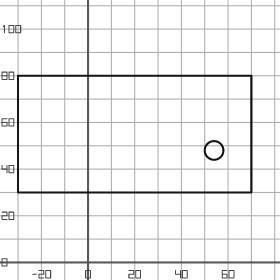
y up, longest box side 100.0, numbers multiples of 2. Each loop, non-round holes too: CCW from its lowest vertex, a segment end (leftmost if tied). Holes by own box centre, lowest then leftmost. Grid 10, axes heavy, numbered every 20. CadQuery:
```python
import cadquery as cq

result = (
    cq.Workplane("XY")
    .moveTo(-30.0, 30.0)
    .lineTo(70.0, 30.0)
    .lineTo(70.0, 80.0)
    .lineTo(-30.0, 80.0)
    .close()
    .moveTo(54.0, 48.0)
    .circle(4.0)
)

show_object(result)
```